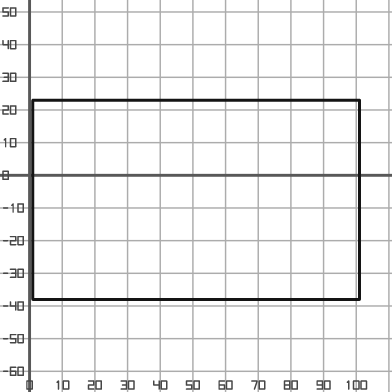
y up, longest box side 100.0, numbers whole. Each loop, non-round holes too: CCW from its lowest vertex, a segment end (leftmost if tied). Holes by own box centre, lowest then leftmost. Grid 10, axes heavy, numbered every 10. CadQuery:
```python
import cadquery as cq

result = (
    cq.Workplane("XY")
    .moveTo(1.0, -38.0)
    .lineTo(101.0, -38.0)
    .lineTo(101.0, 23.0)
    .lineTo(1.0, 23.0)
    .close()
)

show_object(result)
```